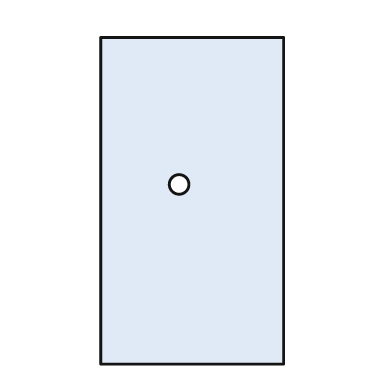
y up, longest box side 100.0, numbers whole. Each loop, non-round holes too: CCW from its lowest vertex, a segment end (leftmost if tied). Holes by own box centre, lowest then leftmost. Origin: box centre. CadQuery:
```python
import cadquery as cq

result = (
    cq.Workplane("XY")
    .moveTo(-28.0, -50.0)
    .lineTo(28.0, -50.0)
    .lineTo(28.0, 50.0)
    .lineTo(-28.0, 50.0)
    .close()
    .moveTo(-4.0, 5.0)
    .circle(3.0)
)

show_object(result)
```